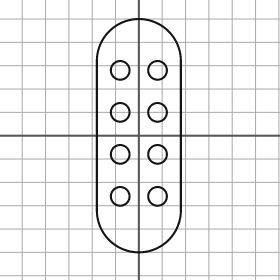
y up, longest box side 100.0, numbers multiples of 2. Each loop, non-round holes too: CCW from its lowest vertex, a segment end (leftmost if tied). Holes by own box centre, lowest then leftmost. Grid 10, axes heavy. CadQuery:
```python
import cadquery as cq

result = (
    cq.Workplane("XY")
    .moveTo(-18.0, -32.0)
    .threePointArc((0.0, -50.0), (18.0, -32.0))
    .lineTo(18.0, 32.0)
    .threePointArc((0.0, 50.0), (-18.0, 32.0))
    .close()
    .moveTo(-8.0, -26.0)
    .circle(4.0)
    .moveTo(8.0, -26.0)
    .circle(4.0)
    .moveTo(-8.0, -8.0)
    .circle(4.0)
    .moveTo(8.0, -8.0)
    .circle(4.0)
    .moveTo(-8.0, 10.0)
    .circle(4.0)
    .moveTo(8.0, 10.0)
    .circle(4.0)
    .moveTo(-8.0, 28.0)
    .circle(4.0)
    .moveTo(8.0, 28.0)
    .circle(4.0)
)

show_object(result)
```